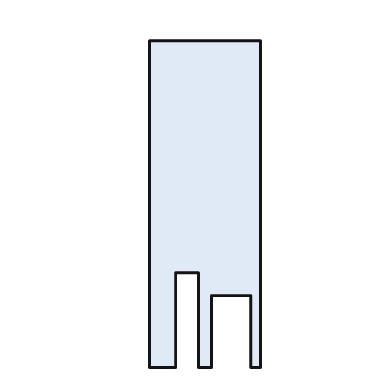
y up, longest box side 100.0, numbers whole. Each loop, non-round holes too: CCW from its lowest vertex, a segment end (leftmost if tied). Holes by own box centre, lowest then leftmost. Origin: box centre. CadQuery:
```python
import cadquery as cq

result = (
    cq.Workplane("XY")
    .moveTo(-17.0, -50.0)
    .lineTo(-9.0, -50.0)
    .lineTo(-9.0, -21.0)
    .lineTo(-2.0, -21.0)
    .lineTo(-2.0, -50.0)
    .lineTo(2.0, -50.0)
    .lineTo(2.0, -28.0)
    .lineTo(14.0, -28.0)
    .lineTo(14.0, -50.0)
    .lineTo(17.0, -50.0)
    .lineTo(17.0, 50.0)
    .lineTo(-17.0, 50.0)
    .close()
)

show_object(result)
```